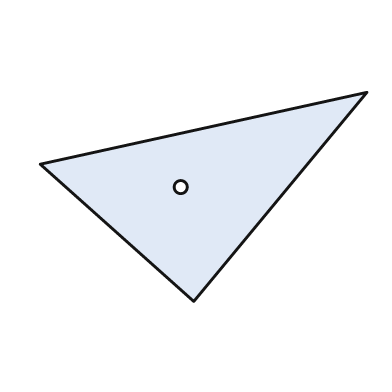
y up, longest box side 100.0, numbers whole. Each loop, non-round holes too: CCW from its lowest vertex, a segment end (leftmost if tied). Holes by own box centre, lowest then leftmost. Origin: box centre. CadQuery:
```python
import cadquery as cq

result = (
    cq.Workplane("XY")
    .moveTo(-3.0, -32.0)
    .lineTo(50.0, 32.0)
    .lineTo(-50.0, 10.0)
    .close()
    .moveTo(-7.0, 3.0)
    .circle(2.0)
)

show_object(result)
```